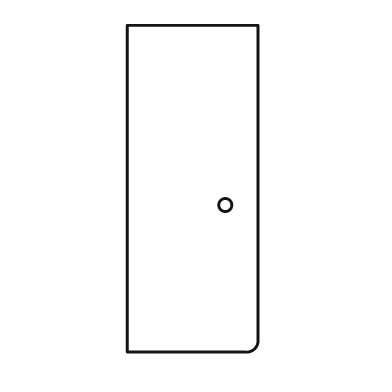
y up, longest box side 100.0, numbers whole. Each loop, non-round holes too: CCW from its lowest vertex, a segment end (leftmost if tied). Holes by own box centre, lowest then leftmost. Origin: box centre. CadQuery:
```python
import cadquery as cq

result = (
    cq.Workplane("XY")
    .moveTo(-20.0, -50.0)
    .lineTo(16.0, -50.0)
    .threePointArc((19.0, -49.0), (20.0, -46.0))
    .lineTo(20.0, 50.0)
    .lineTo(-20.0, 50.0)
    .close()
    .moveTo(10.0, -5.0)
    .circle(2.0)
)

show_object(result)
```